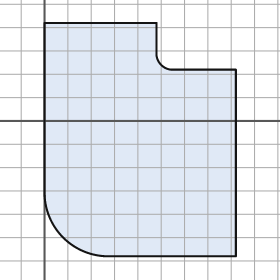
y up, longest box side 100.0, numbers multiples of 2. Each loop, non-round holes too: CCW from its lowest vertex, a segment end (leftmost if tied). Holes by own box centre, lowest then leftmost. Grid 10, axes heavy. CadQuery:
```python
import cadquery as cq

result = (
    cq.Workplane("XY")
    .moveTo(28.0, -58.0)
    .lineTo(82.0, -58.0)
    .lineTo(82.0, 22.0)
    .lineTo(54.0, 22.0)
    .threePointArc((50.0, 24.0), (48.0, 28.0))
    .lineTo(48.0, 42.0)
    .lineTo(0.0, 42.0)
    .lineTo(0.0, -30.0)
    .threePointArc((8.0, -50.0), (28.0, -58.0))
    .close()
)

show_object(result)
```